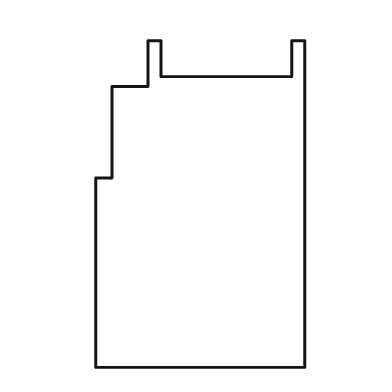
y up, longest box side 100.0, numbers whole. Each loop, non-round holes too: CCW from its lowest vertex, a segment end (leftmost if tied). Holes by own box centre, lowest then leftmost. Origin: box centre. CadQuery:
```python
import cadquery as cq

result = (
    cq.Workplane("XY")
    .moveTo(-32.0, -50.0)
    .lineTo(32.0, -50.0)
    .lineTo(32.0, 50.0)
    .lineTo(28.0, 50.0)
    .lineTo(28.0, 39.0)
    .lineTo(-12.0, 39.0)
    .lineTo(-12.0, 50.0)
    .lineTo(-16.0, 50.0)
    .lineTo(-16.0, 36.0)
    .lineTo(-27.0, 36.0)
    .lineTo(-27.0, 8.0)
    .lineTo(-32.0, 8.0)
    .close()
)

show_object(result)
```